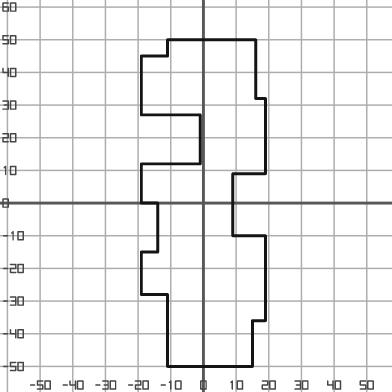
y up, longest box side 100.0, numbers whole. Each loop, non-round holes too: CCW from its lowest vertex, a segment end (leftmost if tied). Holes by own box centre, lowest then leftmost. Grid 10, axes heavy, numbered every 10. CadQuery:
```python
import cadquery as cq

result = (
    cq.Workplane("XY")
    .moveTo(-11.0, -50.0)
    .lineTo(15.0, -50.0)
    .lineTo(15.0, -36.0)
    .lineTo(19.0, -36.0)
    .lineTo(19.0, -10.0)
    .lineTo(9.0, -10.0)
    .lineTo(9.0, 9.0)
    .lineTo(19.0, 9.0)
    .lineTo(19.0, 32.0)
    .lineTo(16.0, 32.0)
    .lineTo(16.0, 50.0)
    .lineTo(-11.0, 50.0)
    .lineTo(-11.0, 45.0)
    .lineTo(-19.0, 45.0)
    .lineTo(-19.0, 27.0)
    .lineTo(-1.0, 27.0)
    .lineTo(-1.0, 12.0)
    .lineTo(-19.0, 12.0)
    .lineTo(-19.0, 0.0)
    .lineTo(-14.0, 0.0)
    .lineTo(-14.0, -15.0)
    .lineTo(-19.0, -15.0)
    .lineTo(-19.0, -28.0)
    .lineTo(-11.0, -28.0)
    .close()
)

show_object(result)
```